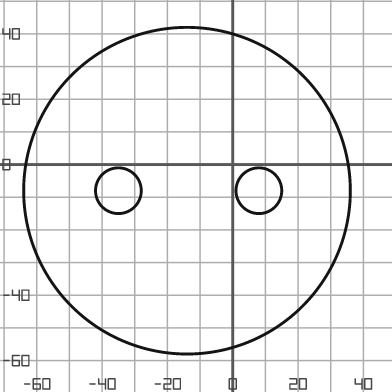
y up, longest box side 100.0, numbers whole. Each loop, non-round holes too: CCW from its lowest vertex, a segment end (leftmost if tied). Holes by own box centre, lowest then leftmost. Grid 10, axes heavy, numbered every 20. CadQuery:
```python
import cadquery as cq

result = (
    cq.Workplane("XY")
    .moveTo(-14.0, -8.0)
    .circle(50.0)
    .moveTo(-35.0, -8.0)
    .circle(7.0)
    .moveTo(8.0, -8.0)
    .circle(7.0)
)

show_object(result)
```